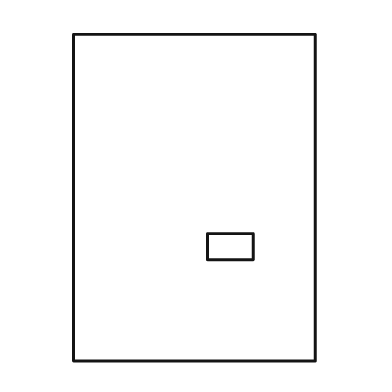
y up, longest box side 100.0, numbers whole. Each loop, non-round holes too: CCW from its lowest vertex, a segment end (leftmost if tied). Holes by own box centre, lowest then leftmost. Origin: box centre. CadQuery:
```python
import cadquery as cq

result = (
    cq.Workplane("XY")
    .moveTo(-37.0, -50.0)
    .lineTo(37.0, -50.0)
    .lineTo(37.0, 50.0)
    .lineTo(-37.0, 50.0)
    .close()
    .moveTo(4.0, -19.0)
    .lineTo(18.0, -19.0)
    .lineTo(18.0, -11.0)
    .lineTo(4.0, -11.0)
    .close()
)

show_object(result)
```